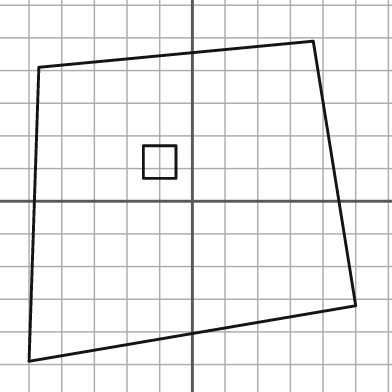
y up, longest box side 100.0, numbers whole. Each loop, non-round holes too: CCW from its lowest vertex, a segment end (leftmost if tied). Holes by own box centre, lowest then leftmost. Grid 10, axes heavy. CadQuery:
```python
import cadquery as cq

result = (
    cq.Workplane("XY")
    .moveTo(-50.0, -49.0)
    .lineTo(50.0, -32.0)
    .lineTo(37.0, 49.0)
    .lineTo(-47.0, 41.0)
    .close()
    .moveTo(-15.0, 7.0)
    .lineTo(-5.0, 7.0)
    .lineTo(-5.0, 17.0)
    .lineTo(-15.0, 17.0)
    .close()
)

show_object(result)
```